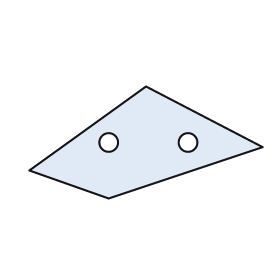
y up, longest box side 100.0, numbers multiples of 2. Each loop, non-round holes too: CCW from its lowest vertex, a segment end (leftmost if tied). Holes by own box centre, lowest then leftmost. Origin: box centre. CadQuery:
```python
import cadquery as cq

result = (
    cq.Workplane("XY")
    .moveTo(-16.0, -24.0)
    .lineTo(50.0, -2.0)
    .lineTo(0.0, 24.0)
    .lineTo(-50.0, -12.0)
    .close()
    .moveTo(-16.0, 0.0)
    .circle(4.0)
    .moveTo(18.0, 0.0)
    .circle(4.0)
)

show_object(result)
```